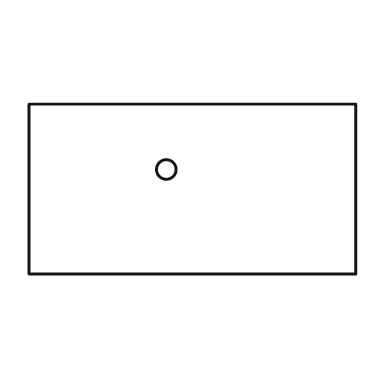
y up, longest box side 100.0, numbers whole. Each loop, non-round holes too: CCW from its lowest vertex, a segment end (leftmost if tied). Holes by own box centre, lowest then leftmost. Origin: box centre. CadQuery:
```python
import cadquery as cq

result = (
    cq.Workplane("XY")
    .moveTo(-50.0, -26.0)
    .lineTo(50.0, -26.0)
    .lineTo(50.0, 26.0)
    .lineTo(-50.0, 26.0)
    .close()
    .moveTo(-8.0, 6.0)
    .circle(3.0)
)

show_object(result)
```